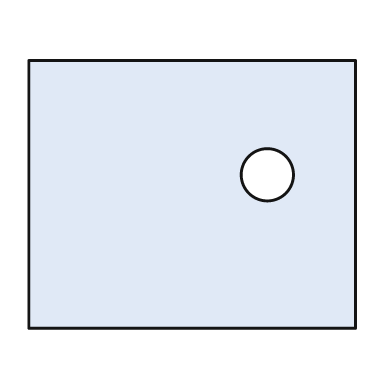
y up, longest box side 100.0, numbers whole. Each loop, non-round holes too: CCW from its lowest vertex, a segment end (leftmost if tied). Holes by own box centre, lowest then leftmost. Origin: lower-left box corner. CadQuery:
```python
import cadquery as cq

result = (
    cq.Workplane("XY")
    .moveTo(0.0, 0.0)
    .lineTo(100.0, 0.0)
    .lineTo(100.0, 82.0)
    .lineTo(0.0, 82.0)
    .close()
    .moveTo(73.0, 47.0)
    .circle(8.0)
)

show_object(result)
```